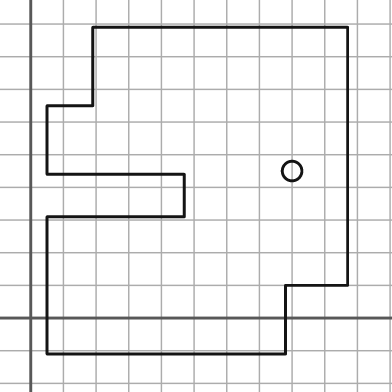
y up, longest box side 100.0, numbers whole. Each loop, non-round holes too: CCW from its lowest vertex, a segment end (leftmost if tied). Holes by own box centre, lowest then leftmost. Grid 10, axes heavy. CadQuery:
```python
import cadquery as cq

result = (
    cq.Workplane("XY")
    .moveTo(5.0, -11.0)
    .lineTo(78.0, -11.0)
    .lineTo(78.0, 10.0)
    .lineTo(97.0, 10.0)
    .lineTo(97.0, 89.0)
    .lineTo(19.0, 89.0)
    .lineTo(19.0, 65.0)
    .lineTo(5.0, 65.0)
    .lineTo(5.0, 44.0)
    .lineTo(47.0, 44.0)
    .lineTo(47.0, 31.0)
    .lineTo(5.0, 31.0)
    .close()
    .moveTo(80.0, 45.0)
    .circle(3.0)
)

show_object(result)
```